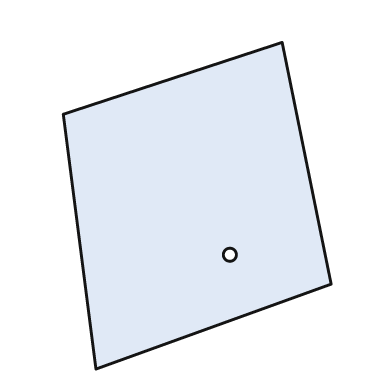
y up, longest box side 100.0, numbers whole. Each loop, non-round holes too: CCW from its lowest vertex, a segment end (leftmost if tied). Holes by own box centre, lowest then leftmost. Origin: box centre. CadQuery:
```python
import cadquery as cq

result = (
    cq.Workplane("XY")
    .moveTo(-31.0, -50.0)
    .lineTo(41.0, -24.0)
    .lineTo(26.0, 50.0)
    .lineTo(-41.0, 28.0)
    .close()
    .moveTo(10.0, -15.0)
    .circle(2.0)
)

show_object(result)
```